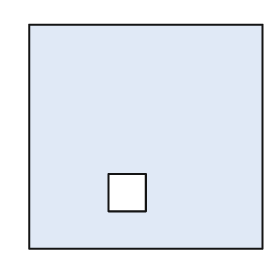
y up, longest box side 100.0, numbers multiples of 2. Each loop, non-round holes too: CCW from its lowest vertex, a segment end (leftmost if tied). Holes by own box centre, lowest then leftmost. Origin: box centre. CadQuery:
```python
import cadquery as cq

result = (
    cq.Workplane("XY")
    .moveTo(-50.0, -48.0)
    .lineTo(50.0, -48.0)
    .lineTo(50.0, 48.0)
    .lineTo(-50.0, 48.0)
    .close()
    .moveTo(-16.0, -32.0)
    .lineTo(0.0, -32.0)
    .lineTo(0.0, -16.0)
    .lineTo(-16.0, -16.0)
    .close()
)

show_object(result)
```